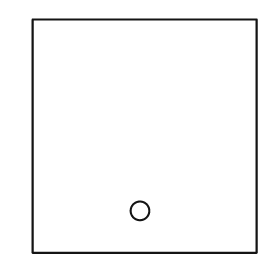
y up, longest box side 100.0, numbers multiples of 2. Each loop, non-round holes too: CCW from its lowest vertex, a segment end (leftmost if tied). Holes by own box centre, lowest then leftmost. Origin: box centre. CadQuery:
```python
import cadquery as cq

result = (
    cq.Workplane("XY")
    .moveTo(-48.0, -50.0)
    .lineTo(48.0, -50.0)
    .lineTo(48.0, 50.0)
    .lineTo(-48.0, 50.0)
    .close()
    .moveTo(-2.0, -32.0)
    .circle(4.0)
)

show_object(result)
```